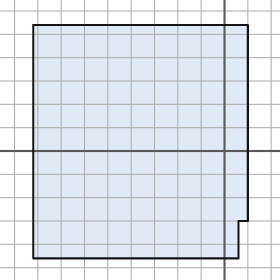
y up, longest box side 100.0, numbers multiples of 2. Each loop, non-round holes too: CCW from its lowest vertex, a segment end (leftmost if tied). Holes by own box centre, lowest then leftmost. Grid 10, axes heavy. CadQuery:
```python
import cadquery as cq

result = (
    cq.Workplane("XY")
    .moveTo(-82.0, -46.0)
    .lineTo(6.0, -46.0)
    .lineTo(6.0, -30.0)
    .lineTo(10.0, -30.0)
    .lineTo(10.0, 54.0)
    .lineTo(-82.0, 54.0)
    .close()
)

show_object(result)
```